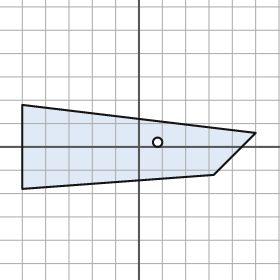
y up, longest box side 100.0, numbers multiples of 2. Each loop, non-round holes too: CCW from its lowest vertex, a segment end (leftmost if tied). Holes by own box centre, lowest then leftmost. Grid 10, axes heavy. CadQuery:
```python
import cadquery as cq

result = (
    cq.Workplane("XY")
    .moveTo(-50.0, -18.0)
    .lineTo(32.0, -12.0)
    .lineTo(50.0, 6.0)
    .lineTo(-50.0, 18.0)
    .close()
    .moveTo(8.0, 2.0)
    .circle(2.0)
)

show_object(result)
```